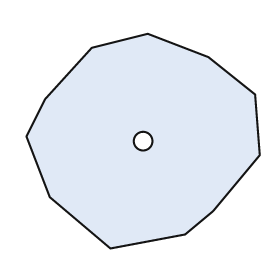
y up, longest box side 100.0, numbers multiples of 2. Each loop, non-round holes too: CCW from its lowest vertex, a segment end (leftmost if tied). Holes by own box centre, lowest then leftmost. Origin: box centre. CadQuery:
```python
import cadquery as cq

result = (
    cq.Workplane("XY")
    .moveTo(-14.0, -46.0)
    .lineTo(18.0, -40.0)
    .lineTo(30.0, -30.0)
    .lineTo(50.0, -6.0)
    .lineTo(48.0, 20.0)
    .lineTo(28.0, 36.0)
    .lineTo(2.0, 46.0)
    .lineTo(-22.0, 40.0)
    .lineTo(-42.0, 18.0)
    .lineTo(-50.0, 2.0)
    .lineTo(-40.0, -24.0)
    .close()
    .moveTo(0.0, 0.0)
    .circle(4.0)
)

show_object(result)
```